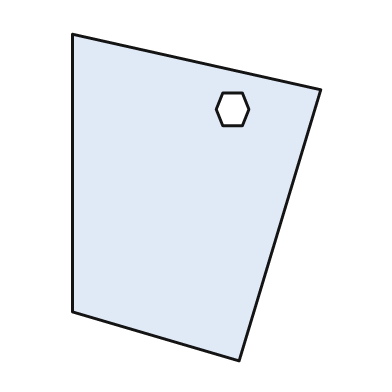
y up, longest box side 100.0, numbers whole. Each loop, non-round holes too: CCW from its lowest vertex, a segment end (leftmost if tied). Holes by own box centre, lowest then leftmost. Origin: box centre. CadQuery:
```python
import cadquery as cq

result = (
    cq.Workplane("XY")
    .moveTo(13.0, -50.0)
    .lineTo(38.0, 33.0)
    .lineTo(-38.0, 50.0)
    .lineTo(-38.0, -35.0)
    .close()
    .moveTo(8.0, 22.0)
    .lineTo(14.0, 22.0)
    .lineTo(16.0, 27.0)
    .lineTo(14.0, 32.0)
    .lineTo(8.0, 32.0)
    .lineTo(6.0, 27.0)
    .close()
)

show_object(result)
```